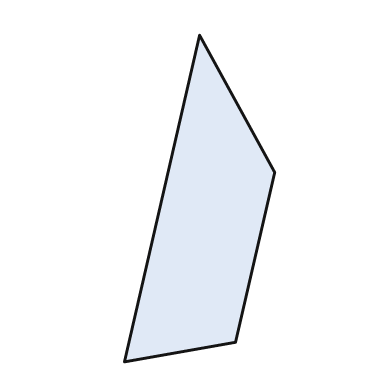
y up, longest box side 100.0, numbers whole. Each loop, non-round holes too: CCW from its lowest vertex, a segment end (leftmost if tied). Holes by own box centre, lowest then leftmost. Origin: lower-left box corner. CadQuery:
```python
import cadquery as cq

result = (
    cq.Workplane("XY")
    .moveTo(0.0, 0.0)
    .lineTo(34.0, 6.0)
    .lineTo(46.0, 58.0)
    .lineTo(23.0, 100.0)
    .close()
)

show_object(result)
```